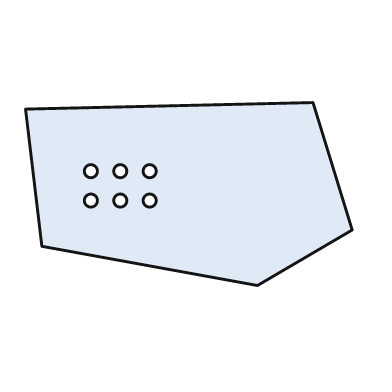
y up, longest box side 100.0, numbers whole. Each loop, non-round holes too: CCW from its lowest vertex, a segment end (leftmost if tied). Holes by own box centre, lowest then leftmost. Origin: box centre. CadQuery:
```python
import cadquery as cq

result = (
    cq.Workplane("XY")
    .moveTo(21.0, -28.0)
    .lineTo(50.0, -11.0)
    .lineTo(38.0, 28.0)
    .lineTo(-50.0, 26.0)
    .lineTo(-45.0, -16.0)
    .close()
    .moveTo(-30.0, -2.0)
    .circle(2.0)
    .moveTo(-21.0, -2.0)
    .circle(2.0)
    .moveTo(-12.0, -2.0)
    .circle(2.0)
    .moveTo(-30.0, 7.0)
    .circle(2.0)
    .moveTo(-21.0, 7.0)
    .circle(2.0)
    .moveTo(-12.0, 7.0)
    .circle(2.0)
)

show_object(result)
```